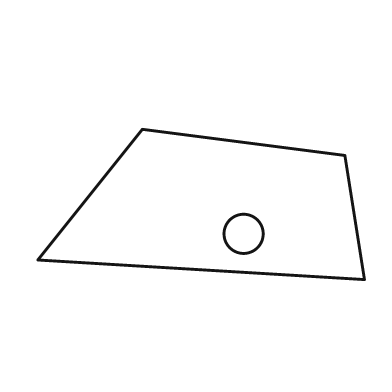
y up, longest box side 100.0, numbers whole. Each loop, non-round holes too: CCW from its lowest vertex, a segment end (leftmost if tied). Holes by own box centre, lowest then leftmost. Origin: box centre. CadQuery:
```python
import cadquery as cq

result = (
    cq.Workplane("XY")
    .moveTo(50.0, -23.0)
    .lineTo(44.0, 15.0)
    .lineTo(-18.0, 23.0)
    .lineTo(-50.0, -17.0)
    .close()
    .moveTo(13.0, -9.0)
    .circle(6.0)
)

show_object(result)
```